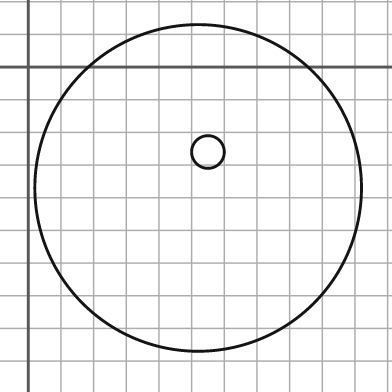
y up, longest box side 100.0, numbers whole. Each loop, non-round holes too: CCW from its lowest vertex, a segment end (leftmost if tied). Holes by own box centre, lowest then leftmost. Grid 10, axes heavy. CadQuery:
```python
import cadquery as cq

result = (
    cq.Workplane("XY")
    .moveTo(52.0, -37.0)
    .circle(50.0)
    .moveTo(55.0, -26.0)
    .circle(5.0)
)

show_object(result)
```